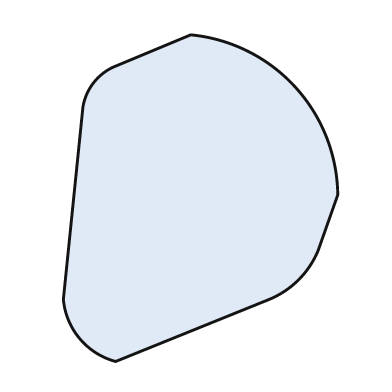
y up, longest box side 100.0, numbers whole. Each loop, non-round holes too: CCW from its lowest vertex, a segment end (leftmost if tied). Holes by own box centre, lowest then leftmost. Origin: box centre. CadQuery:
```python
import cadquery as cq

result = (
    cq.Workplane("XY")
    .moveTo(-26.0, -50.0)
    .lineTo(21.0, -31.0)
    .threePointArc((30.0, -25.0), (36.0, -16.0))
    .lineTo(42.0, 1.0)
    .threePointArc((29.0, 34.0), (-3.0, 50.0))
    .lineTo(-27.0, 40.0)
    .threePointArc((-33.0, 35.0), (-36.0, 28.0))
    .lineTo(-42.0, -31.0)
    .threePointArc((-37.0, -43.0), (-26.0, -50.0))
    .close()
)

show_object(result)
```